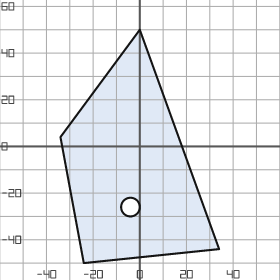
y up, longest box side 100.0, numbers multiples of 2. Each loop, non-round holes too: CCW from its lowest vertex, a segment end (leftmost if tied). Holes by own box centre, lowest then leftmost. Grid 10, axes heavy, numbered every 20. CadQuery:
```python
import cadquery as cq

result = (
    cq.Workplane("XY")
    .moveTo(-24.0, -50.0)
    .lineTo(34.0, -44.0)
    .lineTo(0.0, 50.0)
    .lineTo(-34.0, 4.0)
    .close()
    .moveTo(-4.0, -26.0)
    .circle(4.0)
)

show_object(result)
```